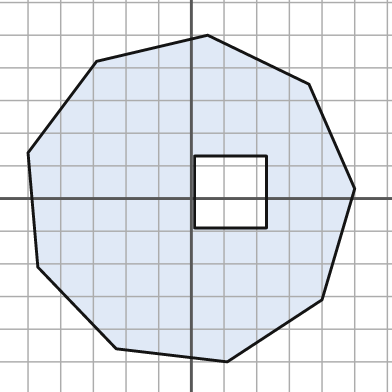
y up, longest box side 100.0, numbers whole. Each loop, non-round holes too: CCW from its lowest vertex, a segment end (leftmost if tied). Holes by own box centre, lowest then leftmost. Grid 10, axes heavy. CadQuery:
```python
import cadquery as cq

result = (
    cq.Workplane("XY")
    .moveTo(11.0, -50.0)
    .lineTo(40.0, -31.0)
    .lineTo(50.0, 3.0)
    .lineTo(36.0, 35.0)
    .lineTo(5.0, 50.0)
    .lineTo(-29.0, 42.0)
    .lineTo(-50.0, 14.0)
    .lineTo(-47.0, -21.0)
    .lineTo(-23.0, -46.0)
    .close()
    .moveTo(1.0, -9.0)
    .lineTo(23.0, -9.0)
    .lineTo(23.0, 13.0)
    .lineTo(1.0, 13.0)
    .close()
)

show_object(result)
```